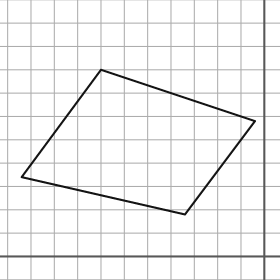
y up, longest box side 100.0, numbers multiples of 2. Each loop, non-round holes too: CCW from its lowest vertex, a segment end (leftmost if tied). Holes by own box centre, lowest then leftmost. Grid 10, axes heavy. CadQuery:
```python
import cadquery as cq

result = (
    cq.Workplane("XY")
    .moveTo(-34.0, 18.0)
    .lineTo(-4.0, 58.0)
    .lineTo(-70.0, 80.0)
    .lineTo(-104.0, 34.0)
    .close()
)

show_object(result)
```